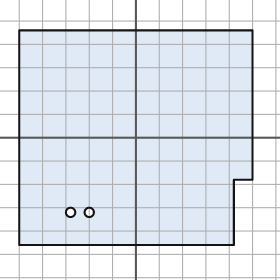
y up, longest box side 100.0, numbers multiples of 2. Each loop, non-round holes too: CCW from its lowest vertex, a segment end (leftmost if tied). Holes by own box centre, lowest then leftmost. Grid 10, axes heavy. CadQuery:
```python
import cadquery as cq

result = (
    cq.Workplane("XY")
    .moveTo(-50.0, -46.0)
    .lineTo(42.0, -46.0)
    .lineTo(42.0, -18.0)
    .lineTo(50.0, -18.0)
    .lineTo(50.0, 46.0)
    .lineTo(-50.0, 46.0)
    .close()
    .moveTo(-28.0, -32.0)
    .circle(2.0)
    .moveTo(-20.0, -32.0)
    .circle(2.0)
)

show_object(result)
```